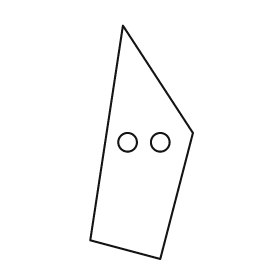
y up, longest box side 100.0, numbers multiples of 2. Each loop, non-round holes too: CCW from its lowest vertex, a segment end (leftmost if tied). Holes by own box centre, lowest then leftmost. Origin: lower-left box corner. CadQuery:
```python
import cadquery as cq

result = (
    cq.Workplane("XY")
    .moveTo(30.0, 0.0)
    .lineTo(44.0, 54.0)
    .lineTo(14.0, 100.0)
    .lineTo(0.0, 8.0)
    .close()
    .moveTo(16.0, 50.0)
    .circle(4.0)
    .moveTo(30.0, 50.0)
    .circle(4.0)
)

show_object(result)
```